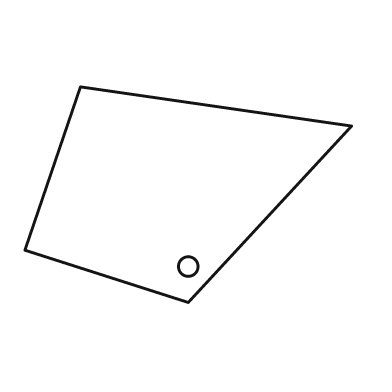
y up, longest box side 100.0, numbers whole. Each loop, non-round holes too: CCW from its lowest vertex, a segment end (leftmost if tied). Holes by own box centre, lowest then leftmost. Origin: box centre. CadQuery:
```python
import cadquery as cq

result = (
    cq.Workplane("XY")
    .moveTo(0.0, -33.0)
    .lineTo(50.0, 21.0)
    .lineTo(-33.0, 33.0)
    .lineTo(-50.0, -17.0)
    .close()
    .moveTo(0.0, -22.0)
    .circle(3.0)
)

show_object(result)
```